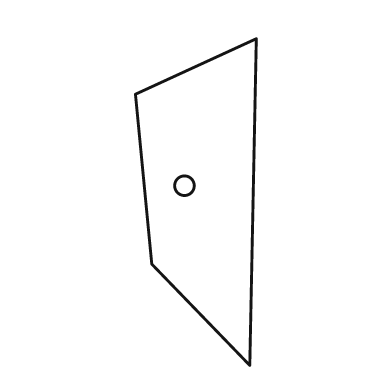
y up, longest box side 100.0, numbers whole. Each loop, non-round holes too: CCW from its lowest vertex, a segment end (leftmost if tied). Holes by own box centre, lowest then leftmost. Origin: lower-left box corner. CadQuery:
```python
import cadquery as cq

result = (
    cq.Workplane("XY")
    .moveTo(35.0, 0.0)
    .lineTo(37.0, 100.0)
    .lineTo(0.0, 83.0)
    .lineTo(5.0, 31.0)
    .close()
    .moveTo(15.0, 55.0)
    .circle(3.0)
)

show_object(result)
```